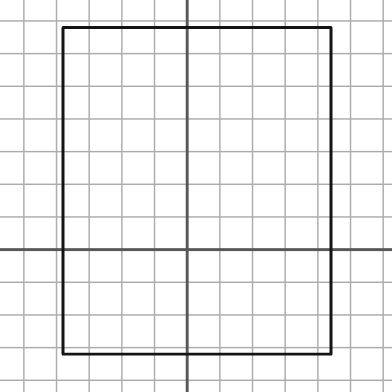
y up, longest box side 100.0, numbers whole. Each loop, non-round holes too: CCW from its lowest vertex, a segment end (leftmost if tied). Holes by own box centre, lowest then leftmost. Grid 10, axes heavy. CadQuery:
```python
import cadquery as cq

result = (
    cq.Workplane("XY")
    .moveTo(-38.0, -32.0)
    .lineTo(44.0, -32.0)
    .lineTo(44.0, 68.0)
    .lineTo(-38.0, 68.0)
    .close()
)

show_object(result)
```